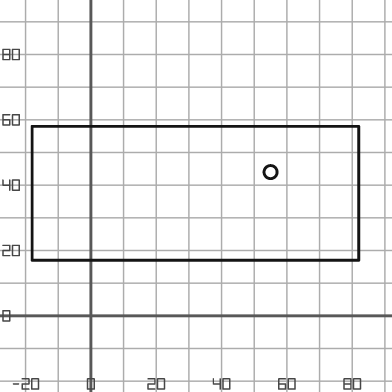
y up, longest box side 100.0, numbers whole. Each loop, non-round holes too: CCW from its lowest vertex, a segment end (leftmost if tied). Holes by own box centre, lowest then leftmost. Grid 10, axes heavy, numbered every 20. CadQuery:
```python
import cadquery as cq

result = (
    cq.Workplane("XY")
    .moveTo(-18.0, 17.0)
    .lineTo(82.0, 17.0)
    .lineTo(82.0, 58.0)
    .lineTo(-18.0, 58.0)
    .close()
    .moveTo(55.0, 44.0)
    .circle(2.0)
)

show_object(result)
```